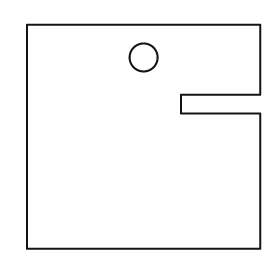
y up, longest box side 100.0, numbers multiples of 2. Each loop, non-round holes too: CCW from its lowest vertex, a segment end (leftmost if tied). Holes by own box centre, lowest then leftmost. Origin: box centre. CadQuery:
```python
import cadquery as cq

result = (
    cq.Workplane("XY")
    .moveTo(-50.0, -48.0)
    .lineTo(50.0, -48.0)
    .lineTo(50.0, 10.0)
    .lineTo(16.0, 10.0)
    .lineTo(16.0, 18.0)
    .lineTo(50.0, 18.0)
    .lineTo(50.0, 48.0)
    .lineTo(-50.0, 48.0)
    .close()
    .moveTo(0.0, 34.0)
    .circle(6.0)
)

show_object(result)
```